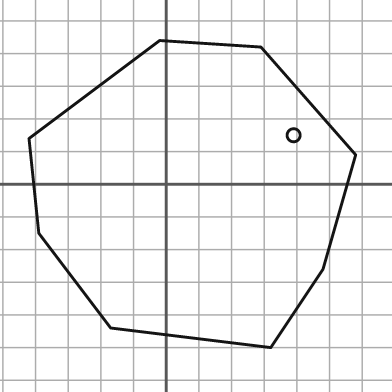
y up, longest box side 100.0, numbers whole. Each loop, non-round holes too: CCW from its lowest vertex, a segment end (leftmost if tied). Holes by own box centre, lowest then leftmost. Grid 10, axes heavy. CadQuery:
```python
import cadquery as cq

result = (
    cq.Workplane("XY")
    .moveTo(32.0, -50.0)
    .lineTo(48.0, -26.0)
    .lineTo(58.0, 9.0)
    .lineTo(29.0, 42.0)
    .lineTo(-2.0, 44.0)
    .lineTo(-42.0, 14.0)
    .lineTo(-39.0, -15.0)
    .lineTo(-17.0, -44.0)
    .close()
    .moveTo(39.0, 15.0)
    .circle(2.0)
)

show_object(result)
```